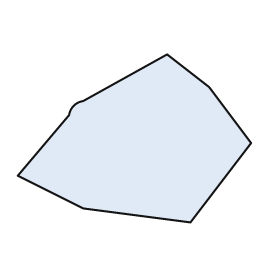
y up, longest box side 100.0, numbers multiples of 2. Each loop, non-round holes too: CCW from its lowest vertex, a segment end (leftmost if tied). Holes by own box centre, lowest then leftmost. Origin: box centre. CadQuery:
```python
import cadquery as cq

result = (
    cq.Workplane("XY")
    .moveTo(24.0, -36.0)
    .lineTo(50.0, -2.0)
    .lineTo(32.0, 22.0)
    .lineTo(14.0, 36.0)
    .lineTo(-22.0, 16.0)
    .threePointArc((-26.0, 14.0), (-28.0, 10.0))
    .lineTo(-50.0, -16.0)
    .lineTo(-22.0, -30.0)
    .close()
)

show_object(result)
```